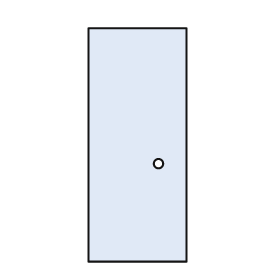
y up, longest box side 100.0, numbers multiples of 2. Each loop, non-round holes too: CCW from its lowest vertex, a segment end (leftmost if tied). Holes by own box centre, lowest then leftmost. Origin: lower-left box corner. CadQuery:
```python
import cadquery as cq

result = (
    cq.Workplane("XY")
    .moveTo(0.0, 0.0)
    .lineTo(42.0, 0.0)
    .lineTo(42.0, 100.0)
    .lineTo(0.0, 100.0)
    .close()
    .moveTo(30.0, 42.0)
    .circle(2.0)
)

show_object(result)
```